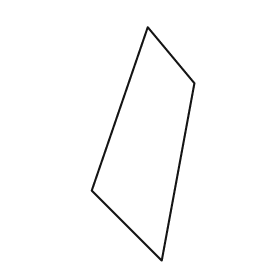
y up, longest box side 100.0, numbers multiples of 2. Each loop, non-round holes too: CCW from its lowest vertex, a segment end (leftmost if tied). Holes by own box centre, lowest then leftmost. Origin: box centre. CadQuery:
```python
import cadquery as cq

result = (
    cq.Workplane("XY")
    .moveTo(8.0, -50.0)
    .lineTo(22.0, 26.0)
    .lineTo(2.0, 50.0)
    .lineTo(-22.0, -20.0)
    .close()
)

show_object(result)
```